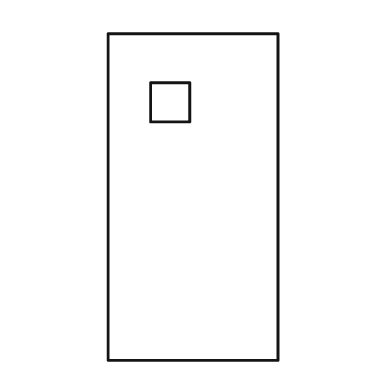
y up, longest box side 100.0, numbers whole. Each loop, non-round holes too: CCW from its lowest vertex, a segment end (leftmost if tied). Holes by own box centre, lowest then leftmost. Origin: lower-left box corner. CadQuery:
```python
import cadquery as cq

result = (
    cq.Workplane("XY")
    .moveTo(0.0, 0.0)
    .lineTo(52.0, 0.0)
    .lineTo(52.0, 100.0)
    .lineTo(0.0, 100.0)
    .close()
    .moveTo(13.0, 73.0)
    .lineTo(25.0, 73.0)
    .lineTo(25.0, 85.0)
    .lineTo(13.0, 85.0)
    .close()
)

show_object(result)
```